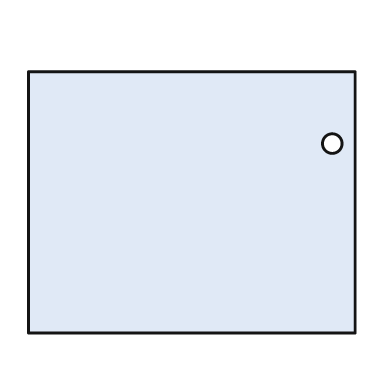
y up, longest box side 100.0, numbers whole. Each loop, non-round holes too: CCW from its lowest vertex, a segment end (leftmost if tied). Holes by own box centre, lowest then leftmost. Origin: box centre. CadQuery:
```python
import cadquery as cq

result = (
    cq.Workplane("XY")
    .moveTo(-50.0, -40.0)
    .lineTo(50.0, -40.0)
    .lineTo(50.0, 40.0)
    .lineTo(-50.0, 40.0)
    .close()
    .moveTo(43.0, 18.0)
    .circle(3.0)
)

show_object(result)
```